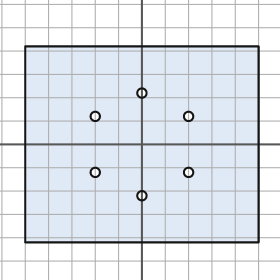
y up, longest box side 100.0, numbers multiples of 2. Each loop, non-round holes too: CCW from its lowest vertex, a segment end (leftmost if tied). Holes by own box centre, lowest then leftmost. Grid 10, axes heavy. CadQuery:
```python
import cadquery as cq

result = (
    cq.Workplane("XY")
    .moveTo(-50.0, -42.0)
    .lineTo(50.0, -42.0)
    .lineTo(50.0, 42.0)
    .lineTo(-50.0, 42.0)
    .close()
    .moveTo(0.0, -22.0)
    .circle(2.0)
    .moveTo(-20.0, -12.0)
    .circle(2.0)
    .moveTo(20.0, -12.0)
    .circle(2.0)
    .moveTo(-20.0, 12.0)
    .circle(2.0)
    .moveTo(20.0, 12.0)
    .circle(2.0)
    .moveTo(0.0, 22.0)
    .circle(2.0)
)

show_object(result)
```